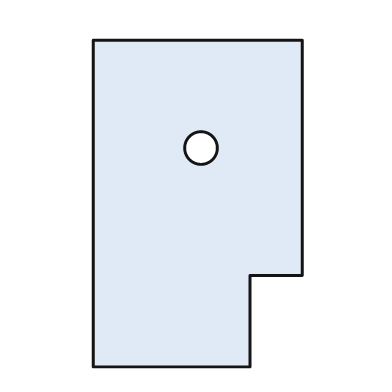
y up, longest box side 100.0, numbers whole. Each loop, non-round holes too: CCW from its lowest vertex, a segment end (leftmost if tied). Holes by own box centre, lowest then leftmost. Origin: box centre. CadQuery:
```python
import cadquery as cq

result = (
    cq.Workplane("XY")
    .moveTo(-32.0, -50.0)
    .lineTo(16.0, -50.0)
    .lineTo(16.0, -22.0)
    .lineTo(32.0, -22.0)
    .lineTo(32.0, 50.0)
    .lineTo(-32.0, 50.0)
    .close()
    .moveTo(1.0, 17.0)
    .circle(5.0)
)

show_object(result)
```